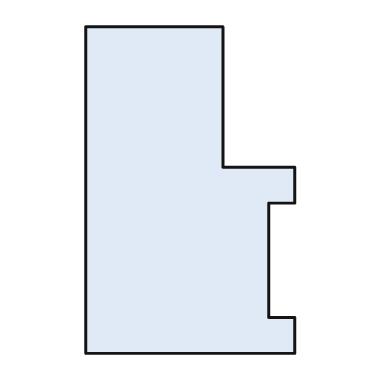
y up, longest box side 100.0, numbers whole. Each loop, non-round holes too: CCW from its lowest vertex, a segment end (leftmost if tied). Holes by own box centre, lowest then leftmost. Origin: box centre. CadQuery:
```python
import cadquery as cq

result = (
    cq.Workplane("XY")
    .moveTo(-32.0, -50.0)
    .lineTo(32.0, -50.0)
    .lineTo(32.0, -39.0)
    .lineTo(24.0, -39.0)
    .lineTo(24.0, -4.0)
    .lineTo(32.0, -4.0)
    .lineTo(32.0, 7.0)
    .lineTo(10.0, 7.0)
    .lineTo(10.0, 50.0)
    .lineTo(-32.0, 50.0)
    .close()
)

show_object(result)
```